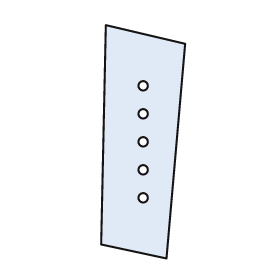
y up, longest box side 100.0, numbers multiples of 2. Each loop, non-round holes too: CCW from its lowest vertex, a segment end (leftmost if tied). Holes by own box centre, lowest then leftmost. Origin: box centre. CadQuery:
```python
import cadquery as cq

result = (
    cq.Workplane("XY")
    .moveTo(10.0, -50.0)
    .lineTo(18.0, 42.0)
    .lineTo(-16.0, 50.0)
    .lineTo(-18.0, -44.0)
    .close()
    .moveTo(0.0, -24.0)
    .circle(2.0)
    .moveTo(0.0, -12.0)
    .circle(2.0)
    .moveTo(0.0, 0.0)
    .circle(2.0)
    .moveTo(0.0, 12.0)
    .circle(2.0)
    .moveTo(0.0, 24.0)
    .circle(2.0)
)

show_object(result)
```